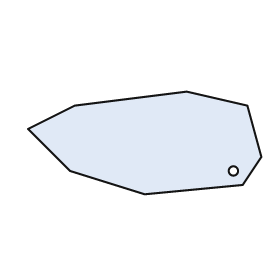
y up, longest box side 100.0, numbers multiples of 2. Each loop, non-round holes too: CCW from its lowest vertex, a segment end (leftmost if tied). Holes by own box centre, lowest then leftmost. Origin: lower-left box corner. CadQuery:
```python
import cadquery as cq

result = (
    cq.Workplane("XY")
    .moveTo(50.0, 0.0)
    .lineTo(92.0, 4.0)
    .lineTo(100.0, 16.0)
    .lineTo(94.0, 38.0)
    .lineTo(68.0, 44.0)
    .lineTo(20.0, 38.0)
    .lineTo(0.0, 28.0)
    .lineTo(18.0, 10.0)
    .close()
    .moveTo(88.0, 10.0)
    .circle(2.0)
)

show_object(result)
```